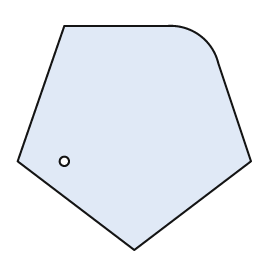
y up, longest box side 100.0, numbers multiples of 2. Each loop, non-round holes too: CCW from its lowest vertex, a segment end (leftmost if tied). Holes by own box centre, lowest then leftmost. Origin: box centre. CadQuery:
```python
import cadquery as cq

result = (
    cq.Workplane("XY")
    .moveTo(0.0, -48.0)
    .lineTo(50.0, -10.0)
    .lineTo(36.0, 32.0)
    .threePointArc((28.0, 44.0), (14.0, 48.0))
    .lineTo(-30.0, 48.0)
    .lineTo(-50.0, -10.0)
    .close()
    .moveTo(-30.0, -10.0)
    .circle(2.0)
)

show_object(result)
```